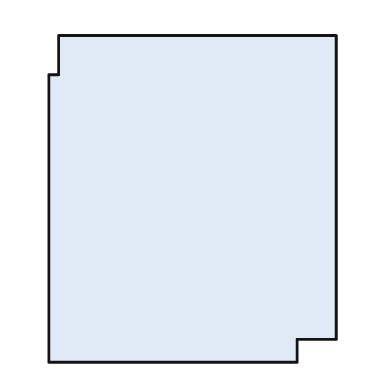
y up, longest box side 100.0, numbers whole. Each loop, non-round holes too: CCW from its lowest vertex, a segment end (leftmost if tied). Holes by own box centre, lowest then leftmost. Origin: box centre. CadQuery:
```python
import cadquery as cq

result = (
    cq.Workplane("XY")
    .moveTo(-44.0, -50.0)
    .lineTo(32.0, -50.0)
    .lineTo(32.0, -43.0)
    .lineTo(44.0, -43.0)
    .lineTo(44.0, 50.0)
    .lineTo(-41.0, 50.0)
    .lineTo(-41.0, 38.0)
    .lineTo(-44.0, 38.0)
    .close()
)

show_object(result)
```